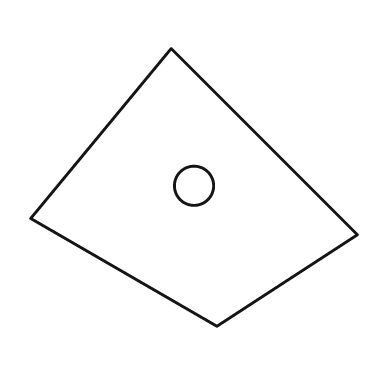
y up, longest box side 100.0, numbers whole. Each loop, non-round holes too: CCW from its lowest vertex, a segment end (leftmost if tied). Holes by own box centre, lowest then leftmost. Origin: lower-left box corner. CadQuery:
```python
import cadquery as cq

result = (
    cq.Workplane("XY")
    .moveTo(57.0, 0.0)
    .lineTo(100.0, 28.0)
    .lineTo(43.0, 85.0)
    .lineTo(0.0, 33.0)
    .close()
    .moveTo(50.0, 43.0)
    .circle(6.0)
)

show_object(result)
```